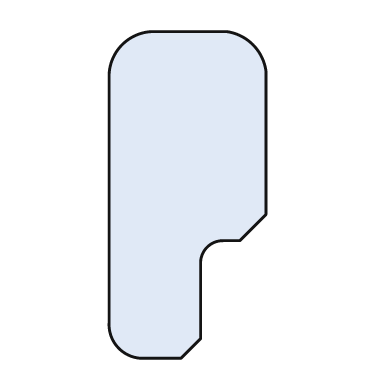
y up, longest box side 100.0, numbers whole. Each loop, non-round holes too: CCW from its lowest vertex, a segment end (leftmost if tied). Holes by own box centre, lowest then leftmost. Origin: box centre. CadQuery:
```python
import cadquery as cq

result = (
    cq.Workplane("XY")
    .moveTo(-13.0, -50.0)
    .lineTo(-2.0, -50.0)
    .lineTo(4.0, -44.0)
    .lineTo(4.0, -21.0)
    .threePointArc((6.0, -16.0), (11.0, -14.0))
    .lineTo(16.0, -14.0)
    .lineTo(24.0, -6.0)
    .lineTo(24.0, 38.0)
    .threePointArc((20.0, 46.0), (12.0, 50.0))
    .lineTo(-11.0, 50.0)
    .threePointArc((-20.0, 46.0), (-24.0, 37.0))
    .lineTo(-24.0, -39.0)
    .threePointArc((-21.0, -47.0), (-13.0, -50.0))
    .close()
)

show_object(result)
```